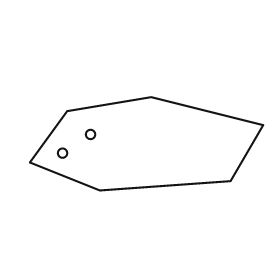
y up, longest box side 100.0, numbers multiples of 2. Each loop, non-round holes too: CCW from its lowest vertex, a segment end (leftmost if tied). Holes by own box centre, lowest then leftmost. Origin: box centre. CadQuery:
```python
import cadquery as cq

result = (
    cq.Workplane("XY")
    .moveTo(-20.0, -20.0)
    .lineTo(36.0, -16.0)
    .lineTo(50.0, 8.0)
    .lineTo(2.0, 20.0)
    .lineTo(-34.0, 14.0)
    .lineTo(-50.0, -8.0)
    .close()
    .moveTo(-36.0, -4.0)
    .circle(2.0)
    .moveTo(-24.0, 4.0)
    .circle(2.0)
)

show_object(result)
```